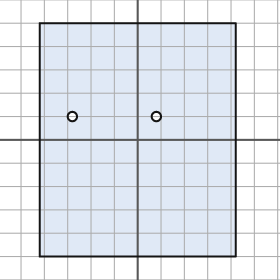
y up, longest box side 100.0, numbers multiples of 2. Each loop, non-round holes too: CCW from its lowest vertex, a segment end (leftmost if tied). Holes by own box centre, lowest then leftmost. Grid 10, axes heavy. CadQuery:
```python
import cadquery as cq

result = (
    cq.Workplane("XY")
    .moveTo(-42.0, -50.0)
    .lineTo(42.0, -50.0)
    .lineTo(42.0, 50.0)
    .lineTo(-42.0, 50.0)
    .close()
    .moveTo(-28.0, 10.0)
    .circle(2.0)
    .moveTo(8.0, 10.0)
    .circle(2.0)
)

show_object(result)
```